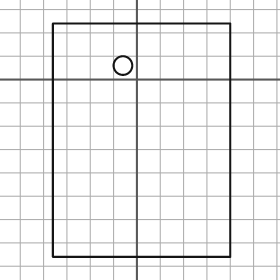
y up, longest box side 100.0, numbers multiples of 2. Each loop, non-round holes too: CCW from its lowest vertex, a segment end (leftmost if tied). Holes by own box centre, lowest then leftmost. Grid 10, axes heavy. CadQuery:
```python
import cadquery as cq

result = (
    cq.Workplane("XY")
    .moveTo(-36.0, -76.0)
    .lineTo(40.0, -76.0)
    .lineTo(40.0, 24.0)
    .lineTo(-36.0, 24.0)
    .close()
    .moveTo(-6.0, 6.0)
    .circle(4.0)
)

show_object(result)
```